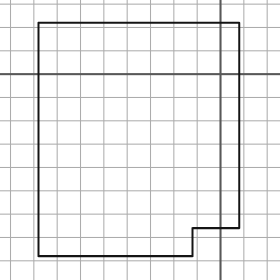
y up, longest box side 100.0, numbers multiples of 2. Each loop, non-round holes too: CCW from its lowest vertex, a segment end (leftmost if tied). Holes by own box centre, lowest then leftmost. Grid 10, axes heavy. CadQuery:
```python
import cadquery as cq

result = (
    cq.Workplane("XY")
    .moveTo(-78.0, -78.0)
    .lineTo(-12.0, -78.0)
    .lineTo(-12.0, -66.0)
    .lineTo(8.0, -66.0)
    .lineTo(8.0, 22.0)
    .lineTo(-78.0, 22.0)
    .close()
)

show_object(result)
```